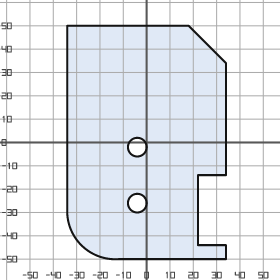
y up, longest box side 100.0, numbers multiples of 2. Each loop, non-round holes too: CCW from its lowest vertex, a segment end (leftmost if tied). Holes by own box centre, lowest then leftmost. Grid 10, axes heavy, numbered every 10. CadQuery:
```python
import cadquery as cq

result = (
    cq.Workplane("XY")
    .moveTo(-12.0, -50.0)
    .lineTo(34.0, -50.0)
    .lineTo(34.0, -44.0)
    .lineTo(22.0, -44.0)
    .lineTo(22.0, -14.0)
    .lineTo(34.0, -14.0)
    .lineTo(34.0, 34.0)
    .lineTo(18.0, 50.0)
    .lineTo(-34.0, 50.0)
    .lineTo(-34.0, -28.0)
    .threePointArc((-28.0, -44.0), (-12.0, -50.0))
    .close()
    .moveTo(-4.0, -26.0)
    .circle(4.0)
    .moveTo(-4.0, -2.0)
    .circle(4.0)
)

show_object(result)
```